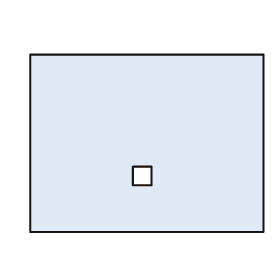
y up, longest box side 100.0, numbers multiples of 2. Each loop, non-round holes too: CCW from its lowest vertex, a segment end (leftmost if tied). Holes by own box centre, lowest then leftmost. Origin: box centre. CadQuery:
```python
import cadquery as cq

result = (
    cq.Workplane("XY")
    .moveTo(-50.0, -38.0)
    .lineTo(50.0, -38.0)
    .lineTo(50.0, 38.0)
    .lineTo(-50.0, 38.0)
    .close()
    .moveTo(-6.0, -18.0)
    .lineTo(2.0, -18.0)
    .lineTo(2.0, -10.0)
    .lineTo(-6.0, -10.0)
    .close()
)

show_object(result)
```